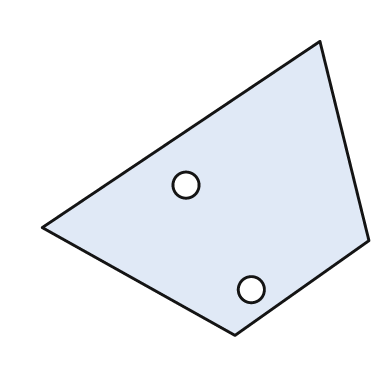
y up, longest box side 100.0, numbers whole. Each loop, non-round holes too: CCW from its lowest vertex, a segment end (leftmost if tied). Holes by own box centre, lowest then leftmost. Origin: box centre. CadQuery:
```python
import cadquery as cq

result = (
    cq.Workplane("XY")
    .moveTo(9.0, -45.0)
    .lineTo(50.0, -16.0)
    .lineTo(35.0, 45.0)
    .lineTo(-50.0, -12.0)
    .close()
    .moveTo(14.0, -31.0)
    .circle(4.0)
    .moveTo(-6.0, 1.0)
    .circle(4.0)
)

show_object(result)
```